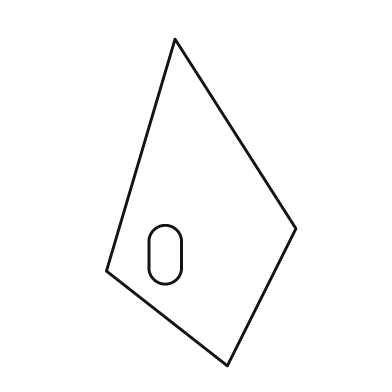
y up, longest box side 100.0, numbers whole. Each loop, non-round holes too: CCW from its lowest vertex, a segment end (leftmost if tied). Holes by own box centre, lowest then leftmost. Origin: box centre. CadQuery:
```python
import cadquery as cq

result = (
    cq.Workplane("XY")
    .moveTo(8.0, -50.0)
    .lineTo(29.0, -8.0)
    .lineTo(-8.0, 50.0)
    .lineTo(-29.0, -21.0)
    .close()
    .moveTo(-16.0, -20.0)
    .threePointArc((-11.0, -25.0), (-6.0, -20.0))
    .lineTo(-6.0, -12.0)
    .threePointArc((-11.0, -7.0), (-16.0, -12.0))
    .close()
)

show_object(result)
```